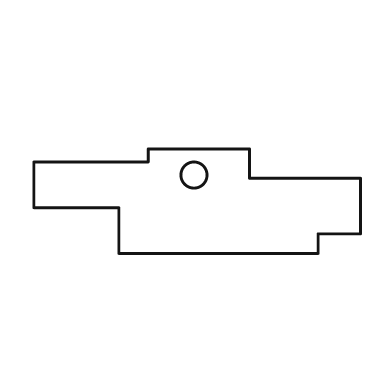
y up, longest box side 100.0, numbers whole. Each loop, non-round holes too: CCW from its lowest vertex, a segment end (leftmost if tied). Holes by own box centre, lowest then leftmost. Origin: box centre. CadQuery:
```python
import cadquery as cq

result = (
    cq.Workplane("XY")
    .moveTo(-24.0, -16.0)
    .lineTo(37.0, -16.0)
    .lineTo(37.0, -10.0)
    .lineTo(50.0, -10.0)
    .lineTo(50.0, 7.0)
    .lineTo(16.0, 7.0)
    .lineTo(16.0, 16.0)
    .lineTo(-15.0, 16.0)
    .lineTo(-15.0, 12.0)
    .lineTo(-50.0, 12.0)
    .lineTo(-50.0, -2.0)
    .lineTo(-24.0, -2.0)
    .close()
    .moveTo(-1.0, 8.0)
    .circle(4.0)
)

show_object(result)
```